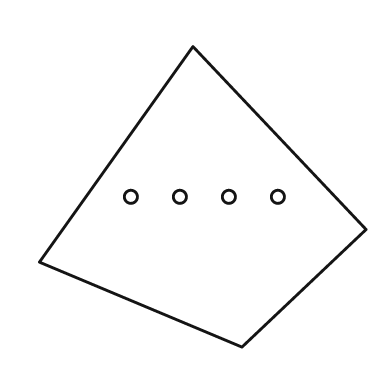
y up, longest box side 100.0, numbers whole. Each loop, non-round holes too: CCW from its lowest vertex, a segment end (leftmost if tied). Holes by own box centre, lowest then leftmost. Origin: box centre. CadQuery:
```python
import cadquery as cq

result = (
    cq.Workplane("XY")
    .moveTo(12.0, -46.0)
    .lineTo(50.0, -10.0)
    .lineTo(-3.0, 46.0)
    .lineTo(-50.0, -20.0)
    .close()
    .moveTo(-22.0, 0.0)
    .circle(2.0)
    .moveTo(-7.0, 0.0)
    .circle(2.0)
    .moveTo(8.0, 0.0)
    .circle(2.0)
    .moveTo(23.0, 0.0)
    .circle(2.0)
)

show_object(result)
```